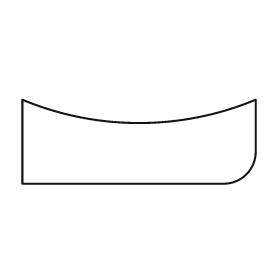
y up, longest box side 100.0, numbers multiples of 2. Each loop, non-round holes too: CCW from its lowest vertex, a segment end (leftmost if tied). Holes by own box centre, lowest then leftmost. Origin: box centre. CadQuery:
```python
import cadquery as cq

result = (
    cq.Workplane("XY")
    .moveTo(-50.0, -18.0)
    .lineTo(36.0, -18.0)
    .threePointArc((46.0, -14.0), (50.0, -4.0))
    .lineTo(50.0, 18.0)
    .threePointArc((0.0, 8.0), (-50.0, 18.0))
    .close()
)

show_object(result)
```